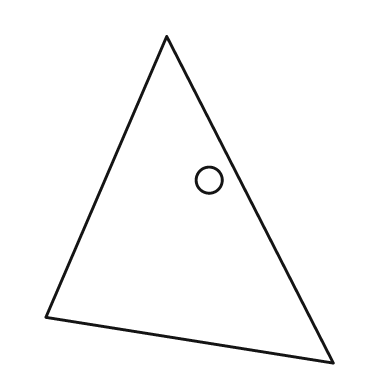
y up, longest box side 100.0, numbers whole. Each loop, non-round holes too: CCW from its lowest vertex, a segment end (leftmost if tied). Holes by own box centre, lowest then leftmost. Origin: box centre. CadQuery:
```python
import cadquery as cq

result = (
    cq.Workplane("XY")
    .moveTo(44.0, -50.0)
    .lineTo(-7.0, 50.0)
    .lineTo(-44.0, -36.0)
    .close()
    .moveTo(6.0, 6.0)
    .circle(4.0)
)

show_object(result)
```